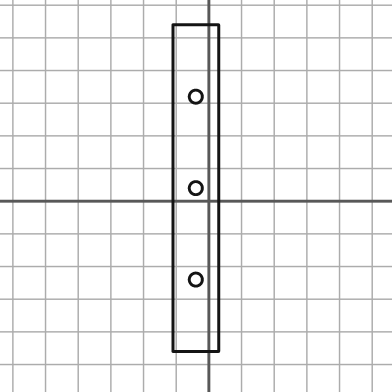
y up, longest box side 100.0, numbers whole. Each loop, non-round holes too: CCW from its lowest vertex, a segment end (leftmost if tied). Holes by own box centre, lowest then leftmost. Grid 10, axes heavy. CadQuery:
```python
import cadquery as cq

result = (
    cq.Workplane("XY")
    .moveTo(-11.0, -46.0)
    .lineTo(3.0, -46.0)
    .lineTo(3.0, 54.0)
    .lineTo(-11.0, 54.0)
    .close()
    .moveTo(-4.0, -24.0)
    .circle(2.0)
    .moveTo(-4.0, 4.0)
    .circle(2.0)
    .moveTo(-4.0, 32.0)
    .circle(2.0)
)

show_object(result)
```